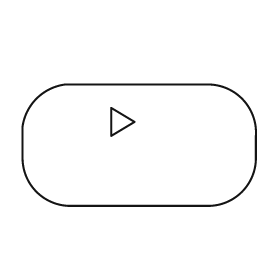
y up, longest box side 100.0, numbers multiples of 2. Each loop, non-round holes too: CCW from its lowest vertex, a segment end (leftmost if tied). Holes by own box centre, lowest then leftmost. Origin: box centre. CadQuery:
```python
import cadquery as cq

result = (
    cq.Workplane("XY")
    .moveTo(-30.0, -26.0)
    .lineTo(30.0, -26.0)
    .threePointArc((44.0, -20.0), (50.0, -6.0))
    .lineTo(50.0, 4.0)
    .threePointArc((44.0, 20.0), (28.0, 26.0))
    .lineTo(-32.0, 26.0)
    .threePointArc((-44.0, 20.0), (-50.0, 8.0))
    .lineTo(-50.0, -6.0)
    .threePointArc((-44.0, -20.0), (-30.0, -26.0))
    .close()
    .moveTo(-12.0, 4.0)
    .lineTo(-2.0, 10.0)
    .lineTo(-12.0, 16.0)
    .close()
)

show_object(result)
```